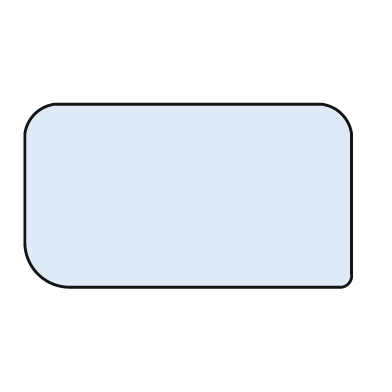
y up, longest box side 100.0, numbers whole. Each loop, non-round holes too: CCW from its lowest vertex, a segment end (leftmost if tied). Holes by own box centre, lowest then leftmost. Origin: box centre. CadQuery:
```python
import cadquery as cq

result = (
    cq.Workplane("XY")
    .moveTo(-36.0, -28.0)
    .lineTo(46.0, -28.0)
    .threePointArc((49.0, -27.0), (50.0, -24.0))
    .lineTo(50.0, 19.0)
    .threePointArc((47.0, 25.0), (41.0, 28.0))
    .lineTo(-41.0, 28.0)
    .threePointArc((-47.0, 25.0), (-50.0, 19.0))
    .lineTo(-50.0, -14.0)
    .threePointArc((-46.0, -24.0), (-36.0, -28.0))
    .close()
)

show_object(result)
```